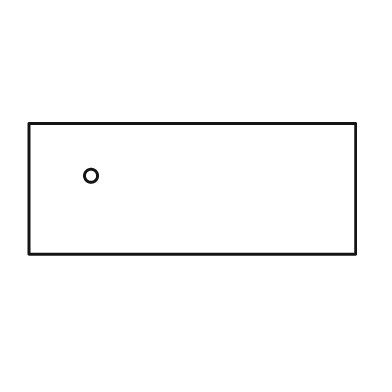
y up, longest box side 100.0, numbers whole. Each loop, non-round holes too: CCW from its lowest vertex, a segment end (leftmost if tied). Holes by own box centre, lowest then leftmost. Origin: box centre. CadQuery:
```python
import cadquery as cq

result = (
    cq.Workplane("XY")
    .moveTo(-50.0, -20.0)
    .lineTo(50.0, -20.0)
    .lineTo(50.0, 20.0)
    .lineTo(-50.0, 20.0)
    .close()
    .moveTo(-31.0, 4.0)
    .circle(2.0)
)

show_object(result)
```